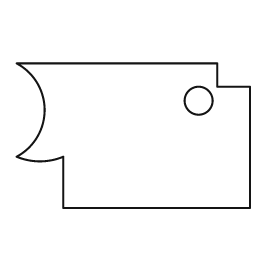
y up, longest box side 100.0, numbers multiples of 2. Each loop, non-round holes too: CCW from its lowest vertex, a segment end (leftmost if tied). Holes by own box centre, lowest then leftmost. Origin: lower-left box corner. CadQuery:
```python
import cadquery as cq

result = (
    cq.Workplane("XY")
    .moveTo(20.0, 0.0)
    .lineTo(100.0, 0.0)
    .lineTo(100.0, 52.0)
    .lineTo(86.0, 52.0)
    .lineTo(86.0, 62.0)
    .lineTo(0.0, 62.0)
    .threePointArc((12.0, 42.0), (0.0, 22.0))
    .threePointArc((10.0, 20.0), (20.0, 22.0))
    .close()
    .moveTo(78.0, 46.0)
    .circle(6.0)
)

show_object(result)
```